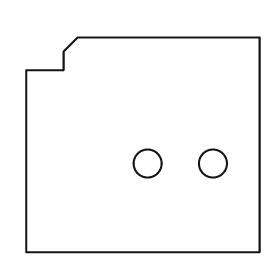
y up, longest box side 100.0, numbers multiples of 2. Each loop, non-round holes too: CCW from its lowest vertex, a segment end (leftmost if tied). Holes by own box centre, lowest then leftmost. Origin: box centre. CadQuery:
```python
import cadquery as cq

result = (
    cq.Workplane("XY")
    .moveTo(-50.0, -46.0)
    .lineTo(50.0, -46.0)
    .lineTo(50.0, 46.0)
    .lineTo(-28.0, 46.0)
    .lineTo(-34.0, 40.0)
    .lineTo(-34.0, 32.0)
    .lineTo(-50.0, 32.0)
    .close()
    .moveTo(2.0, -8.0)
    .circle(6.0)
    .moveTo(30.0, -8.0)
    .circle(6.0)
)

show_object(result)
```